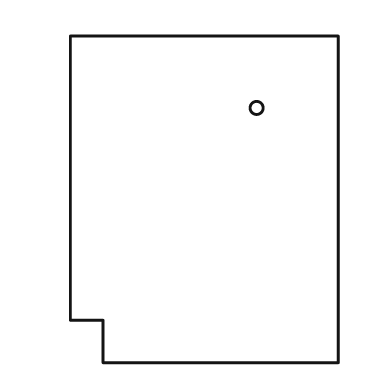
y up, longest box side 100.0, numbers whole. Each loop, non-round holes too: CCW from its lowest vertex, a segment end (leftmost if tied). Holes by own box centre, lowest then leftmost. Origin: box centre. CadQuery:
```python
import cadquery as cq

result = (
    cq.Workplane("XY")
    .moveTo(-31.0, -50.0)
    .lineTo(41.0, -50.0)
    .lineTo(41.0, 50.0)
    .lineTo(-41.0, 50.0)
    .lineTo(-41.0, -37.0)
    .lineTo(-31.0, -37.0)
    .close()
    .moveTo(16.0, 28.0)
    .circle(2.0)
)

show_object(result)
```